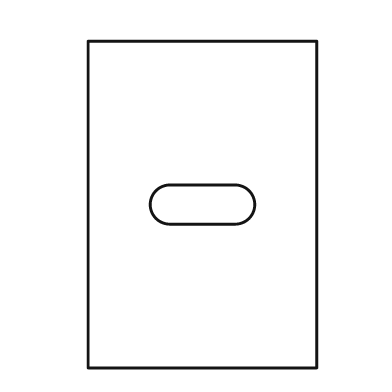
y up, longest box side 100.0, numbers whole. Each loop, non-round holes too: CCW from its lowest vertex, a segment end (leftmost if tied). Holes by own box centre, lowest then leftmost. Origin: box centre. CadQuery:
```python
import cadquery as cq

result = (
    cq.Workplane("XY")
    .moveTo(-35.0, -50.0)
    .lineTo(35.0, -50.0)
    .lineTo(35.0, 50.0)
    .lineTo(-35.0, 50.0)
    .close()
    .moveTo(-10.0, -6.0)
    .lineTo(10.0, -6.0)
    .threePointArc((16.0, 0.0), (10.0, 6.0))
    .lineTo(-10.0, 6.0)
    .threePointArc((-16.0, 0.0), (-10.0, -6.0))
    .close()
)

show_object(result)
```